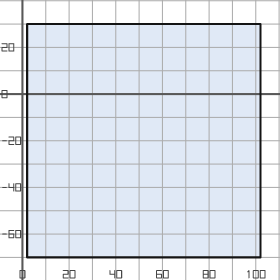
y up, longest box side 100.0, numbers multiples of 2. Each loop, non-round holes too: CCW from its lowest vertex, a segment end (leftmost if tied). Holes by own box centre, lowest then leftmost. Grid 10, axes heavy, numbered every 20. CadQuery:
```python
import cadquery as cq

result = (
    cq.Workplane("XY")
    .moveTo(2.0, -70.0)
    .lineTo(102.0, -70.0)
    .lineTo(102.0, 30.0)
    .lineTo(2.0, 30.0)
    .close()
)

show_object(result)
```